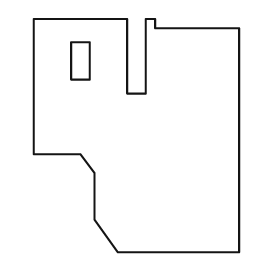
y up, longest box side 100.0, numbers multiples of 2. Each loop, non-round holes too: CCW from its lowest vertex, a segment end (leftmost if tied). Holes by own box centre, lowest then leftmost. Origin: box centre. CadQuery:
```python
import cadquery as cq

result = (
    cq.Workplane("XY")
    .moveTo(-8.0, -50.0)
    .lineTo(44.0, -50.0)
    .lineTo(44.0, 46.0)
    .lineTo(8.0, 46.0)
    .lineTo(8.0, 50.0)
    .lineTo(4.0, 50.0)
    .lineTo(4.0, 18.0)
    .lineTo(-4.0, 18.0)
    .lineTo(-4.0, 50.0)
    .lineTo(-44.0, 50.0)
    .lineTo(-44.0, -8.0)
    .lineTo(-24.0, -8.0)
    .lineTo(-18.0, -16.0)
    .lineTo(-18.0, -36.0)
    .close()
    .moveTo(-28.0, 24.0)
    .lineTo(-20.0, 24.0)
    .lineTo(-20.0, 40.0)
    .lineTo(-28.0, 40.0)
    .close()
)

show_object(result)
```